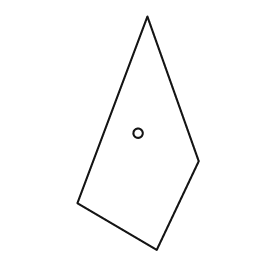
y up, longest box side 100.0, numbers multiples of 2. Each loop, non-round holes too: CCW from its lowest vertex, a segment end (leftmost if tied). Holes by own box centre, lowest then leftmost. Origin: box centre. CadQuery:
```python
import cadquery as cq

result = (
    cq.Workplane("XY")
    .moveTo(8.0, -50.0)
    .lineTo(26.0, -12.0)
    .lineTo(4.0, 50.0)
    .lineTo(-26.0, -30.0)
    .close()
    .moveTo(0.0, 0.0)
    .circle(2.0)
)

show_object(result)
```